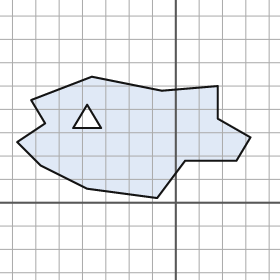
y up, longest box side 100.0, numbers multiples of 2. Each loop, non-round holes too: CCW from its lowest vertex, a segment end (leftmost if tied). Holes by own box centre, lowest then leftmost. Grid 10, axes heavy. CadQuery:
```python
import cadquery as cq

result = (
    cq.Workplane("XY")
    .moveTo(-8.0, 2.0)
    .lineTo(4.0, 18.0)
    .lineTo(26.0, 18.0)
    .lineTo(32.0, 28.0)
    .lineTo(18.0, 36.0)
    .lineTo(18.0, 50.0)
    .lineTo(-6.0, 48.0)
    .lineTo(-36.0, 54.0)
    .lineTo(-62.0, 44.0)
    .lineTo(-56.0, 34.0)
    .lineTo(-68.0, 26.0)
    .lineTo(-58.0, 16.0)
    .lineTo(-38.0, 6.0)
    .close()
    .moveTo(-44.0, 32.0)
    .lineTo(-32.0, 32.0)
    .lineTo(-38.0, 42.0)
    .close()
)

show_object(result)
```